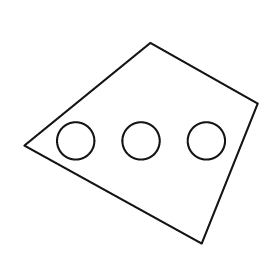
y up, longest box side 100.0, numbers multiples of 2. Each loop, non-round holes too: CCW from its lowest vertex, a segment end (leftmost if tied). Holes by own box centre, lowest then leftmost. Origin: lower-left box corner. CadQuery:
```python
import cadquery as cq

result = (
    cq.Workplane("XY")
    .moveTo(76.0, 0.0)
    .lineTo(100.0, 60.0)
    .lineTo(54.0, 86.0)
    .lineTo(0.0, 42.0)
    .close()
    .moveTo(22.0, 44.0)
    .circle(8.0)
    .moveTo(50.0, 44.0)
    .circle(8.0)
    .moveTo(78.0, 44.0)
    .circle(8.0)
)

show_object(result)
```